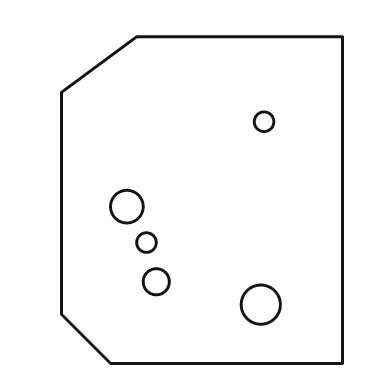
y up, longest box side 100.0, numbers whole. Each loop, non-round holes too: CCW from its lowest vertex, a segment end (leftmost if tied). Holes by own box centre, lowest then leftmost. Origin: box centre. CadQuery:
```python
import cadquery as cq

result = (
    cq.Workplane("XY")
    .moveTo(-28.0, -50.0)
    .lineTo(43.0, -50.0)
    .lineTo(43.0, 50.0)
    .lineTo(-20.0, 50.0)
    .lineTo(-43.0, 33.0)
    .lineTo(-43.0, -35.0)
    .close()
    .moveTo(18.0, -32.0)
    .circle(6.0)
    .moveTo(-14.0, -25.0)
    .circle(4.0)
    .moveTo(-17.0, -13.0)
    .circle(3.0)
    .moveTo(-23.0, -2.0)
    .circle(5.0)
    .moveTo(19.0, 24.0)
    .circle(3.0)
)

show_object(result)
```